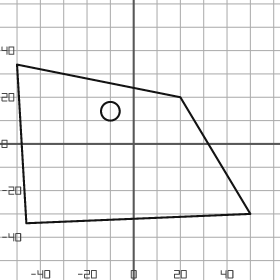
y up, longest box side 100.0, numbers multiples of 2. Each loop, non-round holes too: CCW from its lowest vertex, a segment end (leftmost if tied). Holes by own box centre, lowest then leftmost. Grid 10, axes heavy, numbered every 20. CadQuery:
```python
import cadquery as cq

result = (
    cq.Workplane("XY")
    .moveTo(-46.0, -34.0)
    .lineTo(50.0, -30.0)
    .lineTo(20.0, 20.0)
    .lineTo(-50.0, 34.0)
    .close()
    .moveTo(-10.0, 14.0)
    .circle(4.0)
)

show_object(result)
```